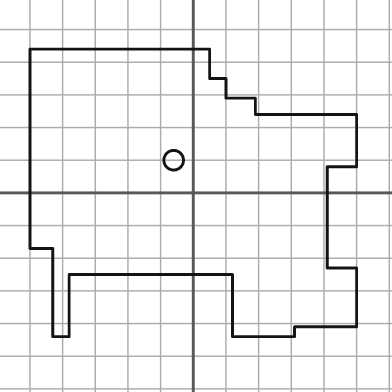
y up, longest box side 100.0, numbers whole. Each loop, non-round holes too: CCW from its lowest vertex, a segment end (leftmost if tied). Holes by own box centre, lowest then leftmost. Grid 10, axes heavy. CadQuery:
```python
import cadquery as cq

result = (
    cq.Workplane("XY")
    .moveTo(-43.0, -44.0)
    .lineTo(-38.0, -44.0)
    .lineTo(-38.0, -25.0)
    .lineTo(12.0, -25.0)
    .lineTo(12.0, -44.0)
    .lineTo(31.0, -44.0)
    .lineTo(31.0, -41.0)
    .lineTo(50.0, -41.0)
    .lineTo(50.0, -23.0)
    .lineTo(41.0, -23.0)
    .lineTo(41.0, 8.0)
    .lineTo(50.0, 8.0)
    .lineTo(50.0, 24.0)
    .lineTo(19.0, 24.0)
    .lineTo(19.0, 29.0)
    .lineTo(10.0, 29.0)
    .lineTo(10.0, 35.0)
    .lineTo(5.0, 35.0)
    .lineTo(5.0, 44.0)
    .lineTo(-50.0, 44.0)
    .lineTo(-50.0, -17.0)
    .lineTo(-43.0, -17.0)
    .close()
    .moveTo(-6.0, 10.0)
    .circle(3.0)
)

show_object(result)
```